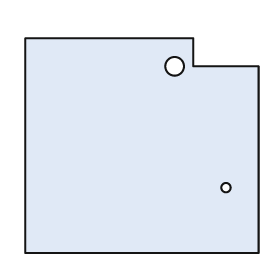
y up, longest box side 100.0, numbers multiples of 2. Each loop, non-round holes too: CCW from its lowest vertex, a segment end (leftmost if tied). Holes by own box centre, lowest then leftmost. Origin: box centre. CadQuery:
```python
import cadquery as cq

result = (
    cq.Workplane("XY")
    .moveTo(-50.0, -46.0)
    .lineTo(50.0, -46.0)
    .lineTo(50.0, 34.0)
    .lineTo(22.0, 34.0)
    .lineTo(22.0, 46.0)
    .lineTo(-50.0, 46.0)
    .close()
    .moveTo(36.0, -18.0)
    .circle(2.0)
    .moveTo(14.0, 34.0)
    .circle(4.0)
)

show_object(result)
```